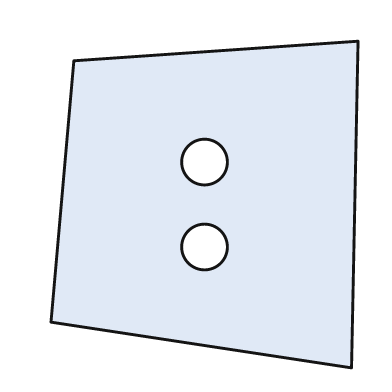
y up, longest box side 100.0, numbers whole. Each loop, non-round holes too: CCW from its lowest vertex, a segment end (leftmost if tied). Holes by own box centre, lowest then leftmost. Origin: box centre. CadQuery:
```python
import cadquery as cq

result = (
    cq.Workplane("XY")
    .moveTo(45.0, -50.0)
    .lineTo(47.0, 50.0)
    .lineTo(-40.0, 44.0)
    .lineTo(-47.0, -36.0)
    .close()
    .moveTo(0.0, -13.0)
    .circle(7.0)
    .moveTo(0.0, 13.0)
    .circle(7.0)
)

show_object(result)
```